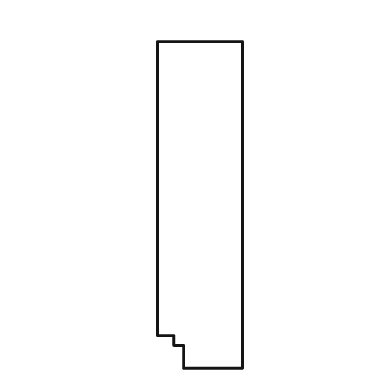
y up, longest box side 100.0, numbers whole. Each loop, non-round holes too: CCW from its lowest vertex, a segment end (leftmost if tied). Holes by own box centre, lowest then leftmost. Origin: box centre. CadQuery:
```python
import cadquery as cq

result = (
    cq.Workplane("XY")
    .moveTo(-5.0, -50.0)
    .lineTo(13.0, -50.0)
    .lineTo(13.0, 50.0)
    .lineTo(-13.0, 50.0)
    .lineTo(-13.0, -40.0)
    .lineTo(-8.0, -40.0)
    .lineTo(-8.0, -43.0)
    .lineTo(-5.0, -43.0)
    .close()
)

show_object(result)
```